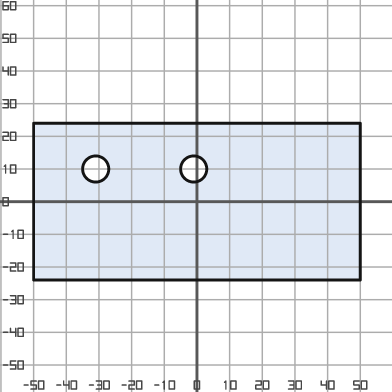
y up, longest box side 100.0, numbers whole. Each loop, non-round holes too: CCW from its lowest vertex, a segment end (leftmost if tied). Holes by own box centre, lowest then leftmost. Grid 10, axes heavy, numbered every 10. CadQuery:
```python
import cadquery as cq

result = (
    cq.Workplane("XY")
    .moveTo(-50.0, -24.0)
    .lineTo(50.0, -24.0)
    .lineTo(50.0, 24.0)
    .lineTo(-50.0, 24.0)
    .close()
    .moveTo(-31.0, 10.0)
    .circle(4.0)
    .moveTo(-1.0, 10.0)
    .circle(4.0)
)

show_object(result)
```